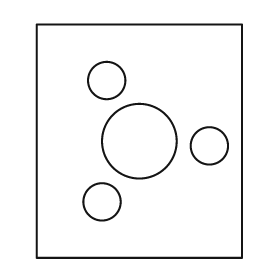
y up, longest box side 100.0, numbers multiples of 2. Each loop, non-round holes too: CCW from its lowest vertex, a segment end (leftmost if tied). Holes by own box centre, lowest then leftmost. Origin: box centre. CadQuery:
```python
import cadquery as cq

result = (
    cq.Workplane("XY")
    .moveTo(-44.0, -50.0)
    .lineTo(44.0, -50.0)
    .lineTo(44.0, 50.0)
    .lineTo(-44.0, 50.0)
    .close()
    .moveTo(-16.0, -26.0)
    .circle(8.0)
    .moveTo(30.0, -2.0)
    .circle(8.0)
    .moveTo(0.0, 0.0)
    .circle(16.0)
    .moveTo(-14.0, 26.0)
    .circle(8.0)
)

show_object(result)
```